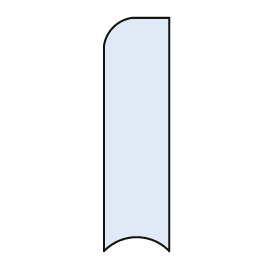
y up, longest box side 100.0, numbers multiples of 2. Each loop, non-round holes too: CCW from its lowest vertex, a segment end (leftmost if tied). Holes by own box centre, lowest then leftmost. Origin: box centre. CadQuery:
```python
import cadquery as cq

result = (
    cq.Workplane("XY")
    .moveTo(-14.0, -50.0)
    .threePointArc((0.0, -44.0), (14.0, -50.0))
    .lineTo(14.0, 50.0)
    .lineTo(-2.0, 50.0)
    .threePointArc((-10.0, 46.0), (-14.0, 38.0))
    .close()
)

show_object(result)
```